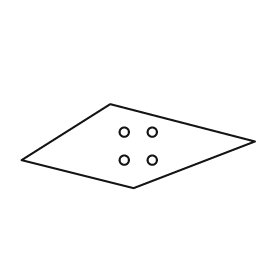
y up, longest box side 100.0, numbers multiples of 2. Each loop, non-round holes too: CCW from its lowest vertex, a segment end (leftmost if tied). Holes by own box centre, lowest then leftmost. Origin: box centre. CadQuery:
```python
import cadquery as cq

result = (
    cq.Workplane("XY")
    .moveTo(-2.0, -18.0)
    .lineTo(50.0, 2.0)
    .lineTo(-12.0, 18.0)
    .lineTo(-50.0, -6.0)
    .close()
    .moveTo(-6.0, -6.0)
    .circle(2.0)
    .moveTo(6.0, -6.0)
    .circle(2.0)
    .moveTo(-6.0, 6.0)
    .circle(2.0)
    .moveTo(6.0, 6.0)
    .circle(2.0)
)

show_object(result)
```